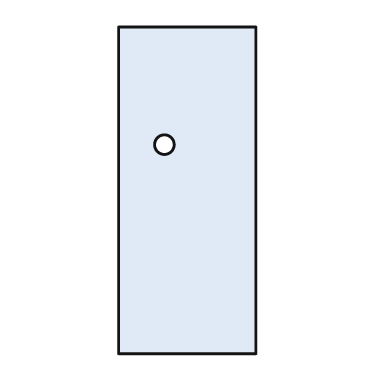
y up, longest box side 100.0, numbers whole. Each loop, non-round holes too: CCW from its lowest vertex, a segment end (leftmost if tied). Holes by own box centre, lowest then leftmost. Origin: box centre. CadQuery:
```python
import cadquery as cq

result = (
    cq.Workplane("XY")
    .moveTo(-21.0, -50.0)
    .lineTo(21.0, -50.0)
    .lineTo(21.0, 50.0)
    .lineTo(-21.0, 50.0)
    .close()
    .moveTo(-7.0, 14.0)
    .circle(3.0)
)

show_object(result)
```